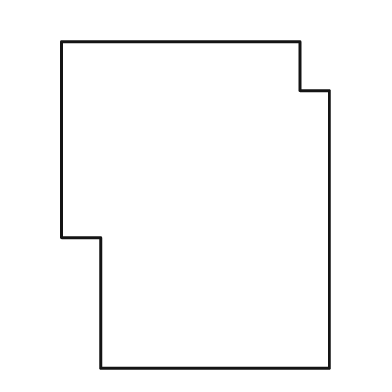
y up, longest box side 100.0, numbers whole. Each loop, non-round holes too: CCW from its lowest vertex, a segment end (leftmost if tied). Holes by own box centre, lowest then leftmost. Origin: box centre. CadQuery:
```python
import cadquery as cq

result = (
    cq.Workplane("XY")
    .moveTo(-29.0, -50.0)
    .lineTo(41.0, -50.0)
    .lineTo(41.0, 35.0)
    .lineTo(32.0, 35.0)
    .lineTo(32.0, 50.0)
    .lineTo(-41.0, 50.0)
    .lineTo(-41.0, -10.0)
    .lineTo(-29.0, -10.0)
    .close()
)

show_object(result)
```